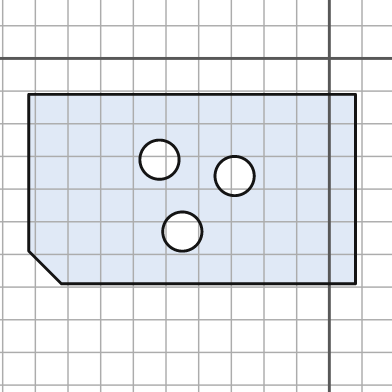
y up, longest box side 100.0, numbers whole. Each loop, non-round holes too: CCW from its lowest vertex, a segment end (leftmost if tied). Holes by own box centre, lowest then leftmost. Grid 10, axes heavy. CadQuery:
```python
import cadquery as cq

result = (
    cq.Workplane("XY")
    .moveTo(-82.0, -69.0)
    .lineTo(8.0, -69.0)
    .lineTo(8.0, -11.0)
    .lineTo(-92.0, -11.0)
    .lineTo(-92.0, -59.0)
    .close()
    .moveTo(-45.0, -53.0)
    .circle(6.0)
    .moveTo(-29.0, -36.0)
    .circle(6.0)
    .moveTo(-52.0, -31.0)
    .circle(6.0)
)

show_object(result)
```